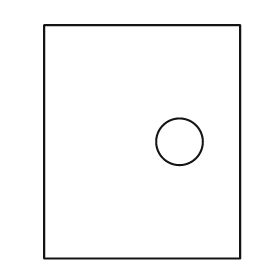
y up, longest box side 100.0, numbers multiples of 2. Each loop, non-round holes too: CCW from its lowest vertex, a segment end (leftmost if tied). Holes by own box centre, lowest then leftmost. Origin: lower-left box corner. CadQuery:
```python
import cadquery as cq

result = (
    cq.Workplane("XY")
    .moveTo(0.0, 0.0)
    .lineTo(84.0, 0.0)
    .lineTo(84.0, 100.0)
    .lineTo(0.0, 100.0)
    .close()
    .moveTo(58.0, 50.0)
    .circle(10.0)
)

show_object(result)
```